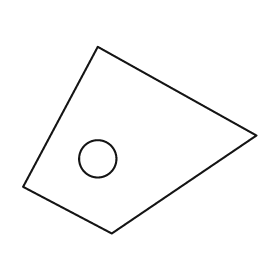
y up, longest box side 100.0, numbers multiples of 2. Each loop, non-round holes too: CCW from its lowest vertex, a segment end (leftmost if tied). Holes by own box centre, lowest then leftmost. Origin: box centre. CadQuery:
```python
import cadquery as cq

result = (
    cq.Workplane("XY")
    .moveTo(-12.0, -40.0)
    .lineTo(50.0, 2.0)
    .lineTo(-18.0, 40.0)
    .lineTo(-50.0, -20.0)
    .close()
    .moveTo(-18.0, -8.0)
    .circle(8.0)
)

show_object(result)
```